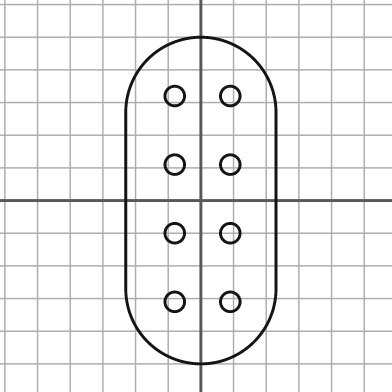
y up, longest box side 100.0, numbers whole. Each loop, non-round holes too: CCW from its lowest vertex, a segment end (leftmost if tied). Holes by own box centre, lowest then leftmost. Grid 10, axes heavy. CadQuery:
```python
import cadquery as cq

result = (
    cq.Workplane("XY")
    .moveTo(-23.0, -27.0)
    .threePointArc((0.0, -50.0), (23.0, -27.0))
    .lineTo(23.0, 27.0)
    .threePointArc((0.0, 50.0), (-23.0, 27.0))
    .close()
    .moveTo(-8.0, -31.0)
    .circle(3.0)
    .moveTo(9.0, -31.0)
    .circle(3.0)
    .moveTo(-8.0, -10.0)
    .circle(3.0)
    .moveTo(9.0, -10.0)
    .circle(3.0)
    .moveTo(-8.0, 11.0)
    .circle(3.0)
    .moveTo(9.0, 11.0)
    .circle(3.0)
    .moveTo(-8.0, 32.0)
    .circle(3.0)
    .moveTo(9.0, 32.0)
    .circle(3.0)
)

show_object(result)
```